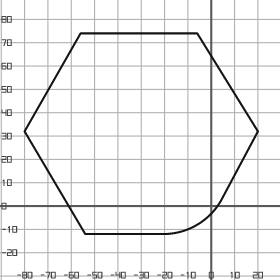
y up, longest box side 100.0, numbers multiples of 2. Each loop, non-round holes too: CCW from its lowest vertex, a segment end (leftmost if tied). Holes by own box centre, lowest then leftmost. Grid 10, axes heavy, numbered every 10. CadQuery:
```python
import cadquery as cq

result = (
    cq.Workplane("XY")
    .moveTo(-54.0, -12.0)
    .lineTo(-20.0, -12.0)
    .threePointArc((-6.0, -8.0), (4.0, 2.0))
    .lineTo(20.0, 32.0)
    .lineTo(-6.0, 74.0)
    .lineTo(-56.0, 74.0)
    .lineTo(-80.0, 32.0)
    .close()
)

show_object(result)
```